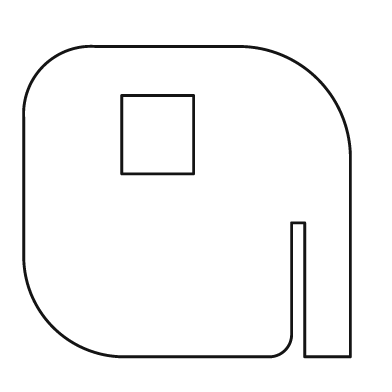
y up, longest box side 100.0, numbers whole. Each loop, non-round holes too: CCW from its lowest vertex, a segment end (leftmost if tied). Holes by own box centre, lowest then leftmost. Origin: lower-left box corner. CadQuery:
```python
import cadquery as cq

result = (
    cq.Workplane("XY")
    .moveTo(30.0, 0.0)
    .lineTo(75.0, 0.0)
    .threePointArc((80.0, 2.0), (82.0, 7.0))
    .lineTo(82.0, 41.0)
    .lineTo(86.0, 41.0)
    .lineTo(86.0, 0.0)
    .lineTo(100.0, 0.0)
    .lineTo(100.0, 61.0)
    .threePointArc((90.0, 85.0), (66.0, 95.0))
    .lineTo(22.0, 95.0)
    .threePointArc((6.0, 89.0), (0.0, 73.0))
    .lineTo(0.0, 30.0)
    .threePointArc((9.0, 9.0), (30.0, 0.0))
    .close()
    .moveTo(30.0, 56.0)
    .lineTo(52.0, 56.0)
    .lineTo(52.0, 80.0)
    .lineTo(30.0, 80.0)
    .close()
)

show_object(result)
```